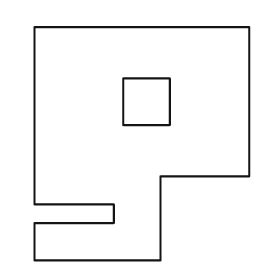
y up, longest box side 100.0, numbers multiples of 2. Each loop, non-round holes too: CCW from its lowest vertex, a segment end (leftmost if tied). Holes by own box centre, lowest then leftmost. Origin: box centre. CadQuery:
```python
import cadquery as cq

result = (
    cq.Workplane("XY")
    .moveTo(-46.0, -50.0)
    .lineTo(8.0, -50.0)
    .lineTo(8.0, -14.0)
    .lineTo(46.0, -14.0)
    .lineTo(46.0, 50.0)
    .lineTo(-46.0, 50.0)
    .lineTo(-46.0, -26.0)
    .lineTo(-12.0, -26.0)
    .lineTo(-12.0, -34.0)
    .lineTo(-46.0, -34.0)
    .close()
    .moveTo(-8.0, 8.0)
    .lineTo(12.0, 8.0)
    .lineTo(12.0, 28.0)
    .lineTo(-8.0, 28.0)
    .close()
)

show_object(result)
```